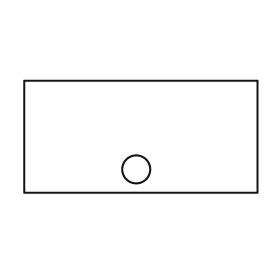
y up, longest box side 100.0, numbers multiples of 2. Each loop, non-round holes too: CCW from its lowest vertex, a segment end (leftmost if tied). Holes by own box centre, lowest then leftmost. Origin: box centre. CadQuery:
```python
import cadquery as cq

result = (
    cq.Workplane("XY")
    .moveTo(-50.0, -24.0)
    .lineTo(50.0, -24.0)
    .lineTo(50.0, 24.0)
    .lineTo(-50.0, 24.0)
    .close()
    .moveTo(-2.0, -14.0)
    .circle(6.0)
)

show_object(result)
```